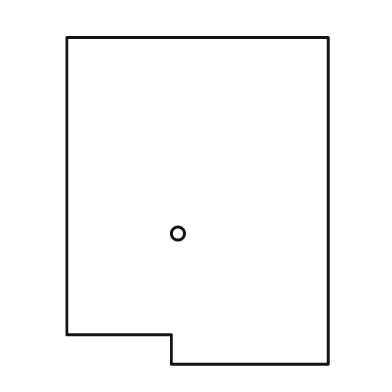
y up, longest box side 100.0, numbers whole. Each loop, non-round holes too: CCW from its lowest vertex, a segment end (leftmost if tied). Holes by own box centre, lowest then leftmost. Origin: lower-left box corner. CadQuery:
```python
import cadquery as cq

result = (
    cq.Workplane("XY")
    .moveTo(32.0, 0.0)
    .lineTo(80.0, 0.0)
    .lineTo(80.0, 100.0)
    .lineTo(0.0, 100.0)
    .lineTo(0.0, 9.0)
    .lineTo(32.0, 9.0)
    .close()
    .moveTo(34.0, 40.0)
    .circle(2.0)
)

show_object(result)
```